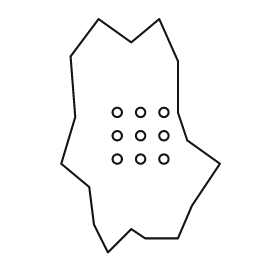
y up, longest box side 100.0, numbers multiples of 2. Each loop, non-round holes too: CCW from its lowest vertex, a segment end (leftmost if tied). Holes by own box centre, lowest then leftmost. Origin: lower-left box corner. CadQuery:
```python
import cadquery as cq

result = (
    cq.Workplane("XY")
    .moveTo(20.0, 0.0)
    .lineTo(30.0, 10.0)
    .lineTo(36.0, 6.0)
    .lineTo(50.0, 6.0)
    .lineTo(56.0, 20.0)
    .lineTo(68.0, 38.0)
    .lineTo(54.0, 48.0)
    .lineTo(50.0, 60.0)
    .lineTo(50.0, 82.0)
    .lineTo(42.0, 100.0)
    .lineTo(30.0, 90.0)
    .lineTo(16.0, 100.0)
    .lineTo(4.0, 84.0)
    .lineTo(6.0, 58.0)
    .lineTo(0.0, 38.0)
    .lineTo(12.0, 28.0)
    .lineTo(14.0, 12.0)
    .close()
    .moveTo(24.0, 40.0)
    .circle(2.0)
    .moveTo(34.0, 40.0)
    .circle(2.0)
    .moveTo(44.0, 40.0)
    .circle(2.0)
    .moveTo(24.0, 50.0)
    .circle(2.0)
    .moveTo(34.0, 50.0)
    .circle(2.0)
    .moveTo(44.0, 50.0)
    .circle(2.0)
    .moveTo(24.0, 60.0)
    .circle(2.0)
    .moveTo(34.0, 60.0)
    .circle(2.0)
    .moveTo(44.0, 60.0)
    .circle(2.0)
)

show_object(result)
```